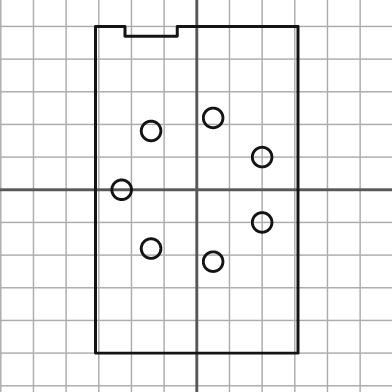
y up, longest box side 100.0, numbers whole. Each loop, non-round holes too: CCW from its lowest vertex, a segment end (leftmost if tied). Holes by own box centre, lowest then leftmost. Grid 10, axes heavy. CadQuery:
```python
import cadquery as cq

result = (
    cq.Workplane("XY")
    .moveTo(-31.0, -50.0)
    .lineTo(31.0, -50.0)
    .lineTo(31.0, 50.0)
    .lineTo(-6.0, 50.0)
    .lineTo(-6.0, 47.0)
    .lineTo(-22.0, 47.0)
    .lineTo(-22.0, 50.0)
    .lineTo(-31.0, 50.0)
    .close()
    .moveTo(5.0, -22.0)
    .circle(3.0)
    .moveTo(-14.0, -18.0)
    .circle(3.0)
    .moveTo(20.0, -10.0)
    .circle(3.0)
    .moveTo(-23.0, 0.0)
    .circle(3.0)
    .moveTo(20.0, 10.0)
    .circle(3.0)
    .moveTo(-14.0, 18.0)
    .circle(3.0)
    .moveTo(5.0, 22.0)
    .circle(3.0)
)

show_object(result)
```